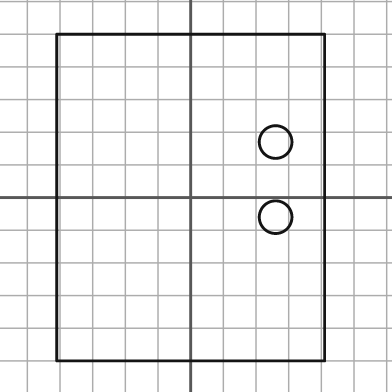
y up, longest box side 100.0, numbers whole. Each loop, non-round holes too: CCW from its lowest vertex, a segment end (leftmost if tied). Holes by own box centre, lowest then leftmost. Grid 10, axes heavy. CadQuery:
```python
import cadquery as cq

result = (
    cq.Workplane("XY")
    .moveTo(-41.0, -50.0)
    .lineTo(41.0, -50.0)
    .lineTo(41.0, 50.0)
    .lineTo(-41.0, 50.0)
    .close()
    .moveTo(26.0, -6.0)
    .circle(5.0)
    .moveTo(26.0, 17.0)
    .circle(5.0)
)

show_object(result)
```